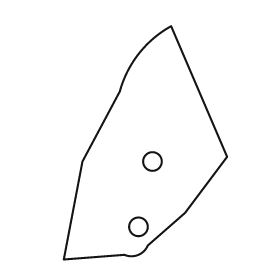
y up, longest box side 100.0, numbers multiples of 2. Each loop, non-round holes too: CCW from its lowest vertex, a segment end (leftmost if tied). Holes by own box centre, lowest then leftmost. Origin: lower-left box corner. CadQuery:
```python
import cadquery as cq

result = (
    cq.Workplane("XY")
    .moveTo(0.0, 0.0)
    .lineTo(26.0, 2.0)
    .threePointArc((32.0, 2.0), (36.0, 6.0))
    .lineTo(52.0, 20.0)
    .lineTo(70.0, 44.0)
    .lineTo(46.0, 100.0)
    .threePointArc((32.0, 88.0), (24.0, 72.0))
    .lineTo(8.0, 42.0)
    .close()
    .moveTo(32.0, 14.0)
    .circle(4.0)
    .moveTo(38.0, 42.0)
    .circle(4.0)
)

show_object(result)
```